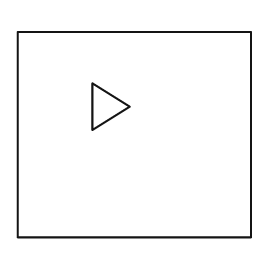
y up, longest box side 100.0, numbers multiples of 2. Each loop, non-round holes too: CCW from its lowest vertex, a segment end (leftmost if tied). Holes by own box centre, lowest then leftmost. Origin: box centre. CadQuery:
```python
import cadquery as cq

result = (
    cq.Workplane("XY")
    .moveTo(-50.0, -44.0)
    .lineTo(50.0, -44.0)
    .lineTo(50.0, 44.0)
    .lineTo(-50.0, 44.0)
    .close()
    .moveTo(-18.0, 2.0)
    .lineTo(-2.0, 12.0)
    .lineTo(-18.0, 22.0)
    .close()
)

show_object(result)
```